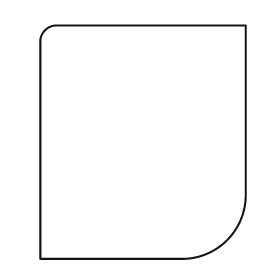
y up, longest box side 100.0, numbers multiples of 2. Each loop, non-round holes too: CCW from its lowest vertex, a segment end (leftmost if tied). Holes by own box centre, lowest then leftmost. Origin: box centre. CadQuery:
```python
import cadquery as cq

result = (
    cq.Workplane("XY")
    .moveTo(-44.0, -50.0)
    .lineTo(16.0, -50.0)
    .threePointArc((36.0, -42.0), (44.0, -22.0))
    .lineTo(44.0, 50.0)
    .lineTo(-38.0, 50.0)
    .threePointArc((-42.0, 48.0), (-44.0, 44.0))
    .close()
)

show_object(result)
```